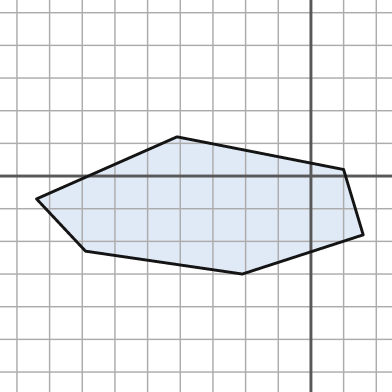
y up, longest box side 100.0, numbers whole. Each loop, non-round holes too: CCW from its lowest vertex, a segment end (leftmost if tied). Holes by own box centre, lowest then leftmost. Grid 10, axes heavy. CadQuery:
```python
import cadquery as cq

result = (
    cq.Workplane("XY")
    .moveTo(-21.0, -30.0)
    .lineTo(16.0, -18.0)
    .lineTo(10.0, 2.0)
    .lineTo(-41.0, 12.0)
    .lineTo(-84.0, -7.0)
    .lineTo(-69.0, -23.0)
    .close()
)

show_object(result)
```